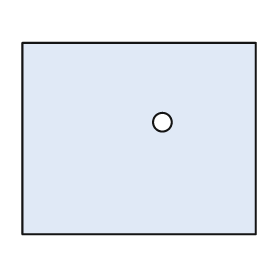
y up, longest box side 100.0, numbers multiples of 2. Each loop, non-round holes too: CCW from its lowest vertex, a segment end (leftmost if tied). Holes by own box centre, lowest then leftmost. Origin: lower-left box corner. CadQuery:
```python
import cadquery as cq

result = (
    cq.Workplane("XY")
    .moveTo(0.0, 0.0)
    .lineTo(100.0, 0.0)
    .lineTo(100.0, 82.0)
    .lineTo(0.0, 82.0)
    .close()
    .moveTo(60.0, 48.0)
    .circle(4.0)
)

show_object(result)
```